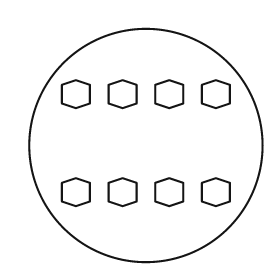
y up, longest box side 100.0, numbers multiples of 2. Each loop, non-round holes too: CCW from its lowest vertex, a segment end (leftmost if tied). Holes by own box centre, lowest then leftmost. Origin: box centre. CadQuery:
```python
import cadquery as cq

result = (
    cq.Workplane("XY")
    .moveTo(0.0, 0.0)
    .circle(50.0)
    .moveTo(-30.0, -26.0)
    .lineTo(-24.0, -24.0)
    .lineTo(-24.0, -16.0)
    .lineTo(-30.0, -14.0)
    .lineTo(-36.0, -16.0)
    .lineTo(-36.0, -24.0)
    .close()
    .moveTo(-10.0, -26.0)
    .lineTo(-4.0, -24.0)
    .lineTo(-4.0, -16.0)
    .lineTo(-10.0, -14.0)
    .lineTo(-16.0, -16.0)
    .lineTo(-16.0, -24.0)
    .close()
    .moveTo(10.0, -26.0)
    .lineTo(16.0, -24.0)
    .lineTo(16.0, -16.0)
    .lineTo(10.0, -14.0)
    .lineTo(4.0, -16.0)
    .lineTo(4.0, -24.0)
    .close()
    .moveTo(30.0, -26.0)
    .lineTo(36.0, -24.0)
    .lineTo(36.0, -16.0)
    .lineTo(30.0, -14.0)
    .lineTo(24.0, -16.0)
    .lineTo(24.0, -24.0)
    .close()
    .moveTo(-30.0, 16.0)
    .lineTo(-24.0, 18.0)
    .lineTo(-24.0, 26.0)
    .lineTo(-30.0, 28.0)
    .lineTo(-36.0, 26.0)
    .lineTo(-36.0, 18.0)
    .close()
    .moveTo(-10.0, 16.0)
    .lineTo(-4.0, 18.0)
    .lineTo(-4.0, 26.0)
    .lineTo(-10.0, 28.0)
    .lineTo(-16.0, 26.0)
    .lineTo(-16.0, 18.0)
    .close()
    .moveTo(10.0, 16.0)
    .lineTo(16.0, 18.0)
    .lineTo(16.0, 26.0)
    .lineTo(10.0, 28.0)
    .lineTo(4.0, 26.0)
    .lineTo(4.0, 18.0)
    .close()
    .moveTo(30.0, 16.0)
    .lineTo(36.0, 18.0)
    .lineTo(36.0, 26.0)
    .lineTo(30.0, 28.0)
    .lineTo(24.0, 26.0)
    .lineTo(24.0, 18.0)
    .close()
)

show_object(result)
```